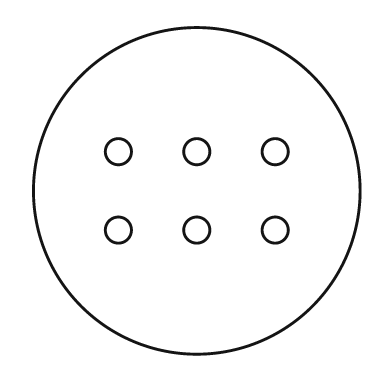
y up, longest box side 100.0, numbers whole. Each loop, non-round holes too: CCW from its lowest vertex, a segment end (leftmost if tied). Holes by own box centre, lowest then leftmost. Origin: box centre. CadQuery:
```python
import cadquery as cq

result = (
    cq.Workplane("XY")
    .moveTo(0.0, 0.0)
    .circle(50.0)
    .moveTo(-24.0, -12.0)
    .circle(4.0)
    .moveTo(0.0, -12.0)
    .circle(4.0)
    .moveTo(24.0, -12.0)
    .circle(4.0)
    .moveTo(-24.0, 12.0)
    .circle(4.0)
    .moveTo(0.0, 12.0)
    .circle(4.0)
    .moveTo(24.0, 12.0)
    .circle(4.0)
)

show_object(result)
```